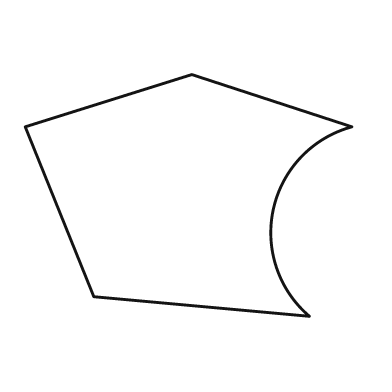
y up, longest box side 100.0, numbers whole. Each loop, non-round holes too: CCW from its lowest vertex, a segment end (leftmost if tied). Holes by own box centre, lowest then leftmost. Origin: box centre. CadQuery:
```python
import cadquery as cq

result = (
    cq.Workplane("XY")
    .moveTo(37.0, -37.0)
    .threePointArc((26.0, -4.0), (50.0, 21.0))
    .lineTo(1.0, 37.0)
    .lineTo(-50.0, 21.0)
    .lineTo(-29.0, -31.0)
    .close()
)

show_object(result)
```